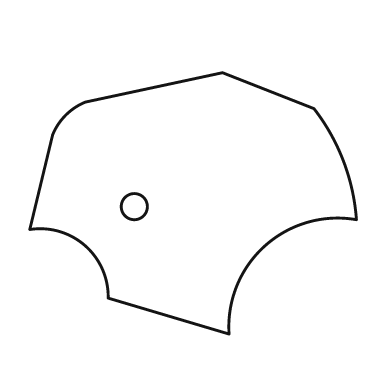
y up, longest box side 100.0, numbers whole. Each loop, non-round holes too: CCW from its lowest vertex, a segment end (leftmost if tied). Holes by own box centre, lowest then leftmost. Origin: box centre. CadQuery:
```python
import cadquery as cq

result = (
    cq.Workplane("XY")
    .moveTo(11.0, -40.0)
    .threePointArc((22.0, -13.0), (50.0, -5.0))
    .threePointArc((46.0, 13.0), (37.0, 29.0))
    .lineTo(9.0, 40.0)
    .lineTo(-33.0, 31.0)
    .threePointArc((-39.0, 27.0), (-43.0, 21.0))
    .lineTo(-50.0, -8.0)
    .threePointArc((-33.0, -13.0), (-26.0, -29.0))
    .close()
    .moveTo(-18.0, -1.0)
    .circle(4.0)
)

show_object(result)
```